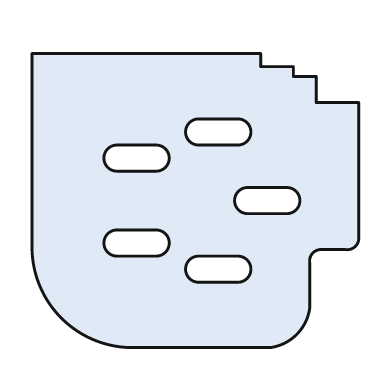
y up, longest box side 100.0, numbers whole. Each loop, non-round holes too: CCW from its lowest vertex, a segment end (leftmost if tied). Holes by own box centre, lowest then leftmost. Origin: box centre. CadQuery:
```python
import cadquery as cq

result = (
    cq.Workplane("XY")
    .moveTo(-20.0, -45.0)
    .lineTo(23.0, -45.0)
    .threePointArc((31.0, -41.0), (35.0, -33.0))
    .lineTo(35.0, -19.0)
    .threePointArc((36.0, -16.0), (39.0, -15.0))
    .lineTo(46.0, -15.0)
    .threePointArc((49.0, -14.0), (50.0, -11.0))
    .lineTo(50.0, 30.0)
    .lineTo(37.0, 30.0)
    .lineTo(37.0, 38.0)
    .lineTo(30.0, 38.0)
    .lineTo(30.0, 41.0)
    .lineTo(20.0, 41.0)
    .lineTo(20.0, 45.0)
    .lineTo(-50.0, 45.0)
    .lineTo(-50.0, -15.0)
    .threePointArc((-41.0, -36.0), (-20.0, -45.0))
    .close()
    .moveTo(1.0, -25.0)
    .lineTo(13.0, -25.0)
    .threePointArc((17.0, -21.0), (13.0, -17.0))
    .lineTo(1.0, -17.0)
    .threePointArc((-3.0, -21.0), (1.0, -25.0))
    .close()
    .moveTo(-24.0, -17.0)
    .lineTo(-12.0, -17.0)
    .threePointArc((-8.0, -13.0), (-12.0, -9.0))
    .lineTo(-24.0, -9.0)
    .threePointArc((-28.0, -13.0), (-24.0, -17.0))
    .close()
    .moveTo(16.0, -4.0)
    .lineTo(28.0, -4.0)
    .threePointArc((32.0, 0.0), (28.0, 4.0))
    .lineTo(16.0, 4.0)
    .threePointArc((12.0, 0.0), (16.0, -4.0))
    .close()
    .moveTo(-24.0, 9.0)
    .lineTo(-12.0, 9.0)
    .threePointArc((-8.0, 13.0), (-12.0, 17.0))
    .lineTo(-24.0, 17.0)
    .threePointArc((-28.0, 13.0), (-24.0, 9.0))
    .close()
    .moveTo(1.0, 17.0)
    .lineTo(13.0, 17.0)
    .threePointArc((17.0, 21.0), (13.0, 25.0))
    .lineTo(1.0, 25.0)
    .threePointArc((-3.0, 21.0), (1.0, 17.0))
    .close()
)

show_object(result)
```